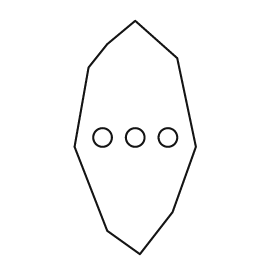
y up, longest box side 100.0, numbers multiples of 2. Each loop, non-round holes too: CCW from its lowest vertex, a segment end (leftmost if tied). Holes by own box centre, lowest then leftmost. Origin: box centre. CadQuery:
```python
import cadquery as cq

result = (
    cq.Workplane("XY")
    .moveTo(2.0, -50.0)
    .lineTo(16.0, -32.0)
    .lineTo(26.0, -4.0)
    .lineTo(18.0, 34.0)
    .lineTo(0.0, 50.0)
    .lineTo(-12.0, 40.0)
    .lineTo(-20.0, 30.0)
    .lineTo(-26.0, -4.0)
    .lineTo(-12.0, -40.0)
    .close()
    .moveTo(-14.0, 0.0)
    .circle(4.0)
    .moveTo(0.0, 0.0)
    .circle(4.0)
    .moveTo(14.0, 0.0)
    .circle(4.0)
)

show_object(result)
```